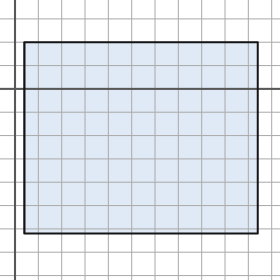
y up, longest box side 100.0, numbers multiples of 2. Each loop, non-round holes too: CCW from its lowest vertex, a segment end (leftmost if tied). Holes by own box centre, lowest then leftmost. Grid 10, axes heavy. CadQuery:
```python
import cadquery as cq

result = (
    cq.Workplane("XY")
    .moveTo(4.0, -62.0)
    .lineTo(104.0, -62.0)
    .lineTo(104.0, 20.0)
    .lineTo(4.0, 20.0)
    .close()
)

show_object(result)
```